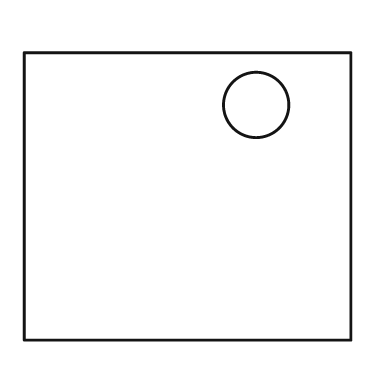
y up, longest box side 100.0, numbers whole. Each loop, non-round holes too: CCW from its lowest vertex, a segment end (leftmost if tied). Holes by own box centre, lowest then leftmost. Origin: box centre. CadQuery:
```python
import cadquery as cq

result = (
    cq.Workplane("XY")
    .moveTo(-50.0, -44.0)
    .lineTo(50.0, -44.0)
    .lineTo(50.0, 44.0)
    .lineTo(-50.0, 44.0)
    .close()
    .moveTo(21.0, 28.0)
    .circle(10.0)
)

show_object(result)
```